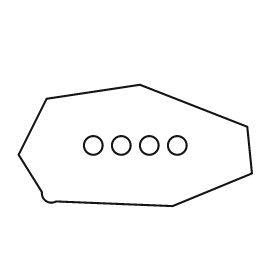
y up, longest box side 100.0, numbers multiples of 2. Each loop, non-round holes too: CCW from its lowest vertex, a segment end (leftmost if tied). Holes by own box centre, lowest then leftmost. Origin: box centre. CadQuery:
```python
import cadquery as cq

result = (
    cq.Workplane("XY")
    .moveTo(16.0, -26.0)
    .lineTo(50.0, -12.0)
    .lineTo(48.0, 8.0)
    .lineTo(2.0, 26.0)
    .lineTo(-38.0, 20.0)
    .lineTo(-50.0, -4.0)
    .lineTo(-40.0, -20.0)
    .threePointArc((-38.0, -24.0), (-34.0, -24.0))
    .close()
    .moveTo(-18.0, 0.0)
    .circle(4.0)
    .moveTo(-6.0, 0.0)
    .circle(4.0)
    .moveTo(6.0, 0.0)
    .circle(4.0)
    .moveTo(18.0, 0.0)
    .circle(4.0)
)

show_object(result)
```